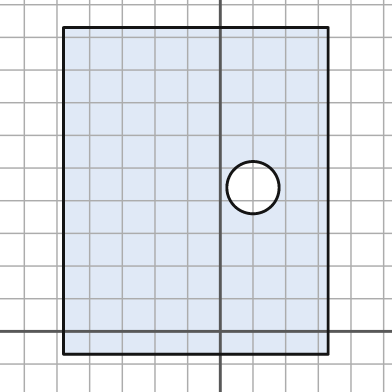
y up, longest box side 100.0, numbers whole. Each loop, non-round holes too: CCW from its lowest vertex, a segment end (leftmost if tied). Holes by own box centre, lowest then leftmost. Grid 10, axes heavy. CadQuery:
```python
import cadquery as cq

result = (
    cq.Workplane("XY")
    .moveTo(-48.0, -7.0)
    .lineTo(33.0, -7.0)
    .lineTo(33.0, 93.0)
    .lineTo(-48.0, 93.0)
    .close()
    .moveTo(10.0, 44.0)
    .circle(8.0)
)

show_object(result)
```